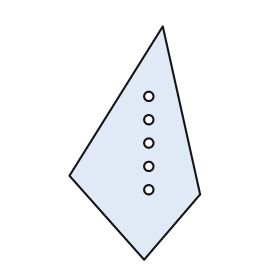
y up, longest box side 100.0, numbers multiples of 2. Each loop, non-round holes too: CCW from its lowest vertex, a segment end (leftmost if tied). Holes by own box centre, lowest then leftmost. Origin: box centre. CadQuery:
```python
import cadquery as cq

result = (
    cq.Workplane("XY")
    .moveTo(4.0, -50.0)
    .lineTo(28.0, -22.0)
    .lineTo(12.0, 50.0)
    .lineTo(-28.0, -14.0)
    .close()
    .moveTo(6.0, -20.0)
    .circle(2.0)
    .moveTo(6.0, -10.0)
    .circle(2.0)
    .moveTo(6.0, 0.0)
    .circle(2.0)
    .moveTo(6.0, 10.0)
    .circle(2.0)
    .moveTo(6.0, 20.0)
    .circle(2.0)
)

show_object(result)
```